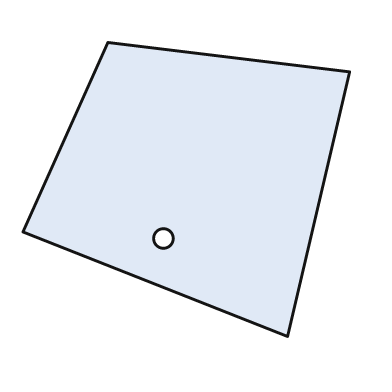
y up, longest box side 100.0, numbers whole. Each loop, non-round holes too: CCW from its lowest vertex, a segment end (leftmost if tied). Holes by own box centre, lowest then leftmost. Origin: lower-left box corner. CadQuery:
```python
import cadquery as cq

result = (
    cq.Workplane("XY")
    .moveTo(81.0, 0.0)
    .lineTo(100.0, 81.0)
    .lineTo(26.0, 90.0)
    .lineTo(0.0, 32.0)
    .close()
    .moveTo(43.0, 30.0)
    .circle(3.0)
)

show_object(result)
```